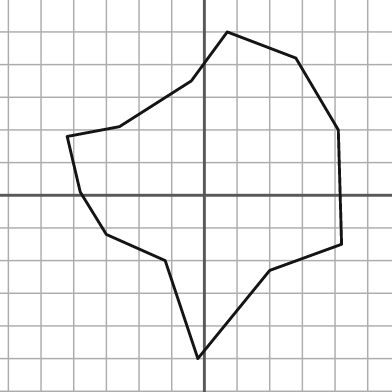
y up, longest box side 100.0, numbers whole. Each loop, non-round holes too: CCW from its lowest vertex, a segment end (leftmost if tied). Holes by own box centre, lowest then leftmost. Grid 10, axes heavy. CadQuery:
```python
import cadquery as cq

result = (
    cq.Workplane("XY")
    .moveTo(-2.0, -50.0)
    .lineTo(20.0, -23.0)
    .lineTo(42.0, -15.0)
    .lineTo(41.0, 20.0)
    .lineTo(28.0, 42.0)
    .lineTo(7.0, 50.0)
    .lineTo(-4.0, 35.0)
    .lineTo(-26.0, 21.0)
    .lineTo(-42.0, 18.0)
    .lineTo(-38.0, 1.0)
    .lineTo(-30.0, -12.0)
    .lineTo(-12.0, -20.0)
    .close()
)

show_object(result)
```